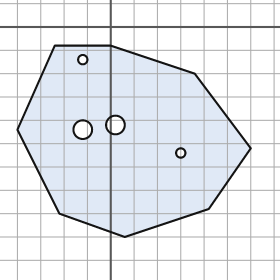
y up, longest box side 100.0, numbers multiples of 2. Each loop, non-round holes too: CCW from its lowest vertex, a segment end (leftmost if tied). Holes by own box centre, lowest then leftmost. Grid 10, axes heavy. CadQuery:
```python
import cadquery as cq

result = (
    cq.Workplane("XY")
    .moveTo(6.0, -90.0)
    .lineTo(42.0, -78.0)
    .lineTo(60.0, -52.0)
    .lineTo(36.0, -20.0)
    .lineTo(0.0, -8.0)
    .lineTo(-24.0, -8.0)
    .lineTo(-40.0, -44.0)
    .lineTo(-22.0, -80.0)
    .close()
    .moveTo(30.0, -54.0)
    .circle(2.0)
    .moveTo(-12.0, -44.0)
    .circle(4.0)
    .moveTo(2.0, -42.0)
    .circle(4.0)
    .moveTo(-12.0, -14.0)
    .circle(2.0)
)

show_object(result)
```